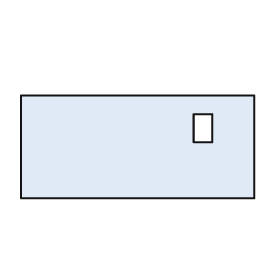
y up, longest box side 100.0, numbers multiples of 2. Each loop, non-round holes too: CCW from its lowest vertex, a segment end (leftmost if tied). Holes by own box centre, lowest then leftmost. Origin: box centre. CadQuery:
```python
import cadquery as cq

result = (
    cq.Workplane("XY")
    .moveTo(-50.0, -22.0)
    .lineTo(50.0, -22.0)
    .lineTo(50.0, 22.0)
    .lineTo(-50.0, 22.0)
    .close()
    .moveTo(24.0, 2.0)
    .lineTo(32.0, 2.0)
    .lineTo(32.0, 14.0)
    .lineTo(24.0, 14.0)
    .close()
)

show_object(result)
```